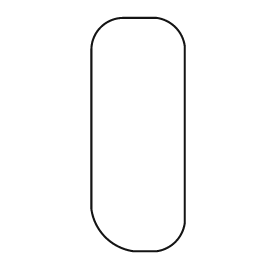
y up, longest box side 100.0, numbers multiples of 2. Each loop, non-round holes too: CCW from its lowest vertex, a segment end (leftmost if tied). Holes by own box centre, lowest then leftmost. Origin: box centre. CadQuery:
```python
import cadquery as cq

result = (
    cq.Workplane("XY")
    .moveTo(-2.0, -50.0)
    .lineTo(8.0, -50.0)
    .threePointArc((16.0, -46.0), (20.0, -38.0))
    .lineTo(20.0, 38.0)
    .threePointArc((16.0, 46.0), (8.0, 50.0))
    .lineTo(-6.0, 50.0)
    .threePointArc((-16.0, 46.0), (-20.0, 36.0))
    .lineTo(-20.0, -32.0)
    .threePointArc((-14.0, -44.0), (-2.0, -50.0))
    .close()
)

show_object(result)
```